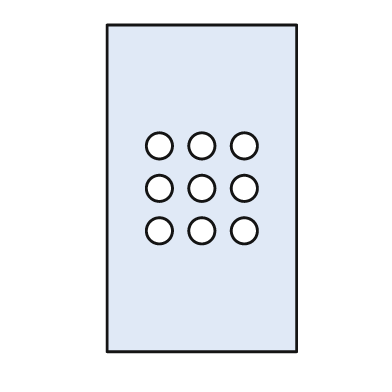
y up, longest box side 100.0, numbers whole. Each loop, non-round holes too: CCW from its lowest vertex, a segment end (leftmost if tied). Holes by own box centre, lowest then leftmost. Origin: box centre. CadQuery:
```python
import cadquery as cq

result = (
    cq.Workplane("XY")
    .moveTo(-29.0, -50.0)
    .lineTo(29.0, -50.0)
    .lineTo(29.0, 50.0)
    .lineTo(-29.0, 50.0)
    .close()
    .moveTo(-13.0, -13.0)
    .circle(4.0)
    .moveTo(0.0, -13.0)
    .circle(4.0)
    .moveTo(13.0, -13.0)
    .circle(4.0)
    .moveTo(-13.0, 0.0)
    .circle(4.0)
    .moveTo(0.0, 0.0)
    .circle(4.0)
    .moveTo(13.0, 0.0)
    .circle(4.0)
    .moveTo(-13.0, 13.0)
    .circle(4.0)
    .moveTo(0.0, 13.0)
    .circle(4.0)
    .moveTo(13.0, 13.0)
    .circle(4.0)
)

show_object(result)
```